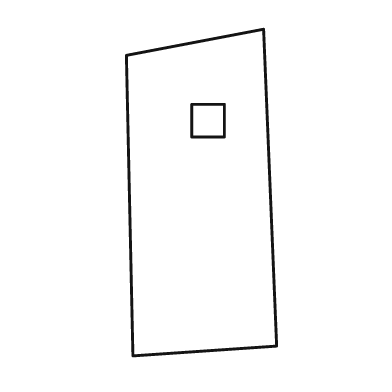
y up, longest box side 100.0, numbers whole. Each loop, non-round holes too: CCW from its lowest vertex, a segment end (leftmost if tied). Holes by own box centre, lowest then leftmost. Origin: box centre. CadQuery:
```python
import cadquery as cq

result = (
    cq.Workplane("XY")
    .moveTo(-21.0, -50.0)
    .lineTo(23.0, -47.0)
    .lineTo(19.0, 50.0)
    .lineTo(-23.0, 42.0)
    .close()
    .moveTo(-3.0, 17.0)
    .lineTo(7.0, 17.0)
    .lineTo(7.0, 27.0)
    .lineTo(-3.0, 27.0)
    .close()
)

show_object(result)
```